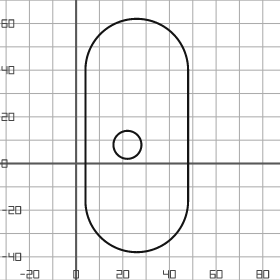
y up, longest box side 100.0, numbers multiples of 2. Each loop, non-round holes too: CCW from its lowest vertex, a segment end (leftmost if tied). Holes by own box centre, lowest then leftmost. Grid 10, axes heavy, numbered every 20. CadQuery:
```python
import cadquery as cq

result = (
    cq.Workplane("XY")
    .moveTo(4.0, -16.0)
    .threePointArc((26.0, -38.0), (48.0, -16.0))
    .lineTo(48.0, 40.0)
    .threePointArc((26.0, 62.0), (4.0, 40.0))
    .close()
    .moveTo(22.0, 8.0)
    .circle(6.0)
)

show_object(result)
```